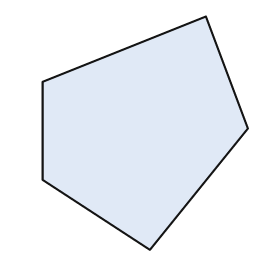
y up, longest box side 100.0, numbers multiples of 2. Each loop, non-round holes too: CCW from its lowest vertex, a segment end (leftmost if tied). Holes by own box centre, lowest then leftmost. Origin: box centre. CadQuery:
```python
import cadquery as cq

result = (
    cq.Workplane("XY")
    .moveTo(2.0, -50.0)
    .lineTo(44.0, 2.0)
    .lineTo(26.0, 50.0)
    .lineTo(-44.0, 22.0)
    .lineTo(-44.0, -20.0)
    .close()
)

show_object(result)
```